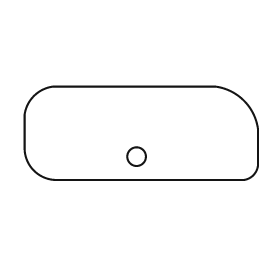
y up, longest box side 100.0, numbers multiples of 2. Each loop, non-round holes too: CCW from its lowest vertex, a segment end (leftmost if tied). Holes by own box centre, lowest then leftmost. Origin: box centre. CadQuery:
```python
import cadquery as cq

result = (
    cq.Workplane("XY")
    .moveTo(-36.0, -20.0)
    .lineTo(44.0, -20.0)
    .threePointArc((48.0, -18.0), (50.0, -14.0))
    .lineTo(50.0, 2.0)
    .threePointArc((44.0, 14.0), (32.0, 20.0))
    .lineTo(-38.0, 20.0)
    .threePointArc((-46.0, 16.0), (-50.0, 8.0))
    .lineTo(-50.0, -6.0)
    .threePointArc((-46.0, -16.0), (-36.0, -20.0))
    .close()
    .moveTo(-2.0, -10.0)
    .circle(4.0)
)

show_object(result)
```